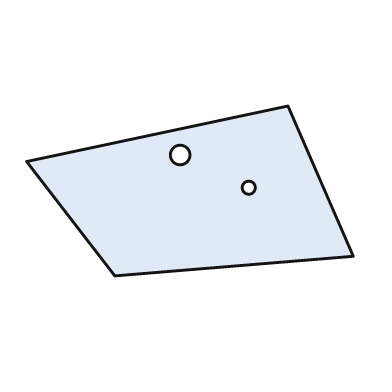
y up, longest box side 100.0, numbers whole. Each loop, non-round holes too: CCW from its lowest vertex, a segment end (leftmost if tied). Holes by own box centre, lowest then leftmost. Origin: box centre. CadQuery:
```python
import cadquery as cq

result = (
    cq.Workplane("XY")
    .moveTo(-23.0, -26.0)
    .lineTo(50.0, -20.0)
    .lineTo(30.0, 26.0)
    .lineTo(-50.0, 9.0)
    .close()
    .moveTo(18.0, 1.0)
    .circle(2.0)
    .moveTo(-3.0, 11.0)
    .circle(3.0)
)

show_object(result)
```